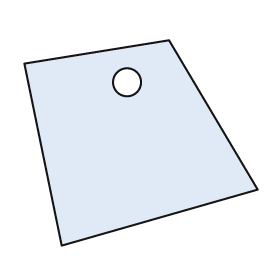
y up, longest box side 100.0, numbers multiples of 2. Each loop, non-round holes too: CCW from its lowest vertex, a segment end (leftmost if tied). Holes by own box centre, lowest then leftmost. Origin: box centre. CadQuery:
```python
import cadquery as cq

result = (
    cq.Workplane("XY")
    .moveTo(-34.0, -44.0)
    .lineTo(50.0, -20.0)
    .lineTo(12.0, 44.0)
    .lineTo(-50.0, 34.0)
    .close()
    .moveTo(-6.0, 26.0)
    .circle(6.0)
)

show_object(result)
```